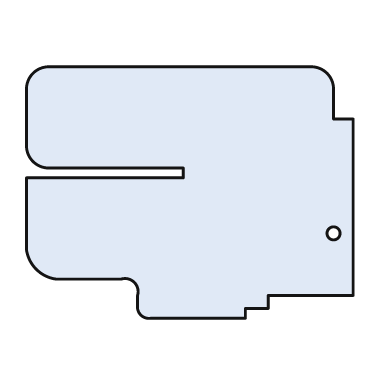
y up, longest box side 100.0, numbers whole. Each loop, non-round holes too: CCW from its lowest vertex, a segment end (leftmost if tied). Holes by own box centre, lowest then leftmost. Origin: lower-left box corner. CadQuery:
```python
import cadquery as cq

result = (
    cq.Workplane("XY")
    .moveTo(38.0, 0.0)
    .lineTo(67.0, 0.0)
    .lineTo(67.0, 3.0)
    .lineTo(74.0, 3.0)
    .lineTo(74.0, 7.0)
    .lineTo(100.0, 7.0)
    .lineTo(100.0, 61.0)
    .lineTo(94.0, 61.0)
    .lineTo(94.0, 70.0)
    .threePointArc((92.0, 75.0), (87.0, 77.0))
    .lineTo(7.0, 77.0)
    .threePointArc((2.0, 75.0), (0.0, 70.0))
    .lineTo(0.0, 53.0)
    .threePointArc((2.0, 48.0), (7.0, 46.0))
    .lineTo(48.0, 46.0)
    .lineTo(48.0, 43.0)
    .lineTo(0.0, 43.0)
    .lineTo(0.0, 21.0)
    .threePointArc((3.0, 15.0), (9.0, 12.0))
    .lineTo(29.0, 12.0)
    .threePointArc((33.0, 11.0), (34.0, 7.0))
    .lineTo(34.0, 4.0)
    .threePointArc((35.0, 1.0), (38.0, 0.0))
    .close()
    .moveTo(94.0, 26.0)
    .circle(2.0)
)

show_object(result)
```